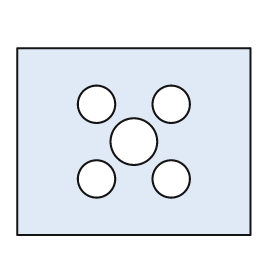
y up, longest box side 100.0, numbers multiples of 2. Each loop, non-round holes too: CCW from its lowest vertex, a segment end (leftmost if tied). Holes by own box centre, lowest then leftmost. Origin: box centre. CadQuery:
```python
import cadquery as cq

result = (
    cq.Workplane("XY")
    .moveTo(-50.0, -40.0)
    .lineTo(50.0, -40.0)
    .lineTo(50.0, 40.0)
    .lineTo(-50.0, 40.0)
    .close()
    .moveTo(-16.0, -16.0)
    .circle(8.0)
    .moveTo(16.0, -16.0)
    .circle(8.0)
    .moveTo(0.0, 0.0)
    .circle(10.0)
    .moveTo(-16.0, 16.0)
    .circle(8.0)
    .moveTo(16.0, 16.0)
    .circle(8.0)
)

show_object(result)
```